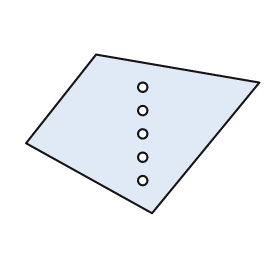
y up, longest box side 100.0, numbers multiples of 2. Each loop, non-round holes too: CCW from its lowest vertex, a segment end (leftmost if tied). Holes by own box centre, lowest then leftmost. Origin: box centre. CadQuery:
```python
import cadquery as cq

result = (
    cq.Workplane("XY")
    .moveTo(4.0, -34.0)
    .lineTo(50.0, 22.0)
    .lineTo(-20.0, 34.0)
    .lineTo(-50.0, -4.0)
    .close()
    .moveTo(0.0, -20.0)
    .circle(2.0)
    .moveTo(0.0, -10.0)
    .circle(2.0)
    .moveTo(0.0, 0.0)
    .circle(2.0)
    .moveTo(0.0, 10.0)
    .circle(2.0)
    .moveTo(0.0, 20.0)
    .circle(2.0)
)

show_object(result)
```